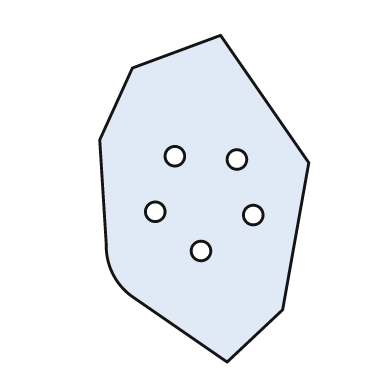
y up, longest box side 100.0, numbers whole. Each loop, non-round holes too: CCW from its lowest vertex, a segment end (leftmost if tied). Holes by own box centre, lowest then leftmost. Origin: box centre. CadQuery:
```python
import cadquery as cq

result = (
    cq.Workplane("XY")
    .moveTo(7.0, -50.0)
    .lineTo(24.0, -34.0)
    .lineTo(32.0, 11.0)
    .lineTo(5.0, 50.0)
    .lineTo(-22.0, 40.0)
    .lineTo(-32.0, 18.0)
    .lineTo(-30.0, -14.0)
    .threePointArc((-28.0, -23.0), (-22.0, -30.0))
    .close()
    .moveTo(-1.0, -16.0)
    .circle(3.0)
    .moveTo(15.0, -5.0)
    .circle(3.0)
    .moveTo(-15.0, -4.0)
    .circle(3.0)
    .moveTo(10.0, 12.0)
    .circle(3.0)
    .moveTo(-9.0, 13.0)
    .circle(3.0)
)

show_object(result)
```